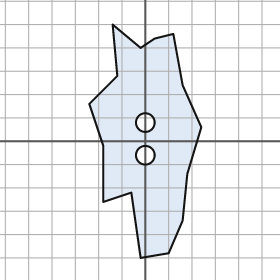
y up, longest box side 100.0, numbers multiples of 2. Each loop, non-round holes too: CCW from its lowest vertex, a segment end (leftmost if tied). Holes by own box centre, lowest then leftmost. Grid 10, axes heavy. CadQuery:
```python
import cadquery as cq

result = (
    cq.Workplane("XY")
    .moveTo(-2.0, -50.0)
    .lineTo(10.0, -48.0)
    .lineTo(16.0, -34.0)
    .lineTo(18.0, -14.0)
    .lineTo(24.0, 6.0)
    .lineTo(16.0, 24.0)
    .lineTo(12.0, 46.0)
    .lineTo(4.0, 44.0)
    .lineTo(-2.0, 40.0)
    .lineTo(-14.0, 50.0)
    .lineTo(-12.0, 28.0)
    .lineTo(-24.0, 16.0)
    .lineTo(-18.0, -2.0)
    .lineTo(-18.0, -26.0)
    .lineTo(-6.0, -22.0)
    .close()
    .moveTo(0.0, -6.0)
    .circle(4.0)
    .moveTo(0.0, 8.0)
    .circle(4.0)
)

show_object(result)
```